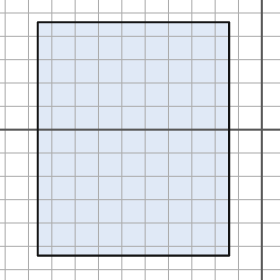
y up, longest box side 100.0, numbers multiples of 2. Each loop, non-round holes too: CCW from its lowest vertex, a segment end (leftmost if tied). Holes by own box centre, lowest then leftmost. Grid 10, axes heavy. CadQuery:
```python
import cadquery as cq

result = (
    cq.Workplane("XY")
    .moveTo(-96.0, -54.0)
    .lineTo(-14.0, -54.0)
    .lineTo(-14.0, 46.0)
    .lineTo(-96.0, 46.0)
    .close()
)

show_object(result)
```